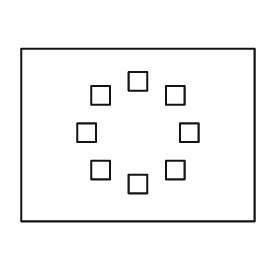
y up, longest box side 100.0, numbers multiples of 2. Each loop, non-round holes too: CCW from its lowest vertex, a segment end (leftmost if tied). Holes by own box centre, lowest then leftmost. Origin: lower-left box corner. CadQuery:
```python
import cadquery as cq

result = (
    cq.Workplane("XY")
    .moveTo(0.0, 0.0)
    .lineTo(100.0, 0.0)
    .lineTo(100.0, 74.0)
    .lineTo(0.0, 74.0)
    .close()
    .moveTo(46.0, 12.0)
    .lineTo(54.0, 12.0)
    .lineTo(54.0, 20.0)
    .lineTo(46.0, 20.0)
    .close()
    .moveTo(30.0, 18.0)
    .lineTo(38.0, 18.0)
    .lineTo(38.0, 26.0)
    .lineTo(30.0, 26.0)
    .close()
    .moveTo(62.0, 18.0)
    .lineTo(70.0, 18.0)
    .lineTo(70.0, 26.0)
    .lineTo(62.0, 26.0)
    .close()
    .moveTo(24.0, 34.0)
    .lineTo(32.0, 34.0)
    .lineTo(32.0, 42.0)
    .lineTo(24.0, 42.0)
    .close()
    .moveTo(68.0, 34.0)
    .lineTo(76.0, 34.0)
    .lineTo(76.0, 42.0)
    .lineTo(68.0, 42.0)
    .close()
    .moveTo(30.0, 50.0)
    .lineTo(38.0, 50.0)
    .lineTo(38.0, 58.0)
    .lineTo(30.0, 58.0)
    .close()
    .moveTo(62.0, 50.0)
    .lineTo(70.0, 50.0)
    .lineTo(70.0, 58.0)
    .lineTo(62.0, 58.0)
    .close()
    .moveTo(46.0, 56.0)
    .lineTo(54.0, 56.0)
    .lineTo(54.0, 64.0)
    .lineTo(46.0, 64.0)
    .close()
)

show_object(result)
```